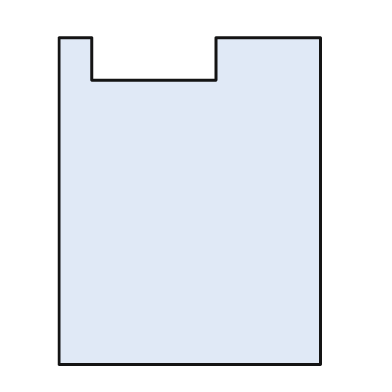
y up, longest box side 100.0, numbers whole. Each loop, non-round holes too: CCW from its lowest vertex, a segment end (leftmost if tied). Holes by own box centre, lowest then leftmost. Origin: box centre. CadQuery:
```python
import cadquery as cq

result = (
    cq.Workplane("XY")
    .moveTo(-40.0, -50.0)
    .lineTo(40.0, -50.0)
    .lineTo(40.0, 50.0)
    .lineTo(8.0, 50.0)
    .lineTo(8.0, 37.0)
    .lineTo(-30.0, 37.0)
    .lineTo(-30.0, 50.0)
    .lineTo(-40.0, 50.0)
    .close()
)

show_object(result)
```